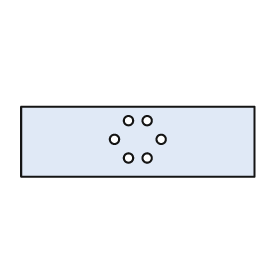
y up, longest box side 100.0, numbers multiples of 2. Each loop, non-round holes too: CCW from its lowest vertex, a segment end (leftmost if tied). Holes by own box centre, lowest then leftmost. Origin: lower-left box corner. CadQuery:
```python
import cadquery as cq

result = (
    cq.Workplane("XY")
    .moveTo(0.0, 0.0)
    .lineTo(100.0, 0.0)
    .lineTo(100.0, 30.0)
    .lineTo(0.0, 30.0)
    .close()
    .moveTo(46.0, 8.0)
    .circle(2.0)
    .moveTo(54.0, 8.0)
    .circle(2.0)
    .moveTo(40.0, 16.0)
    .circle(2.0)
    .moveTo(60.0, 16.0)
    .circle(2.0)
    .moveTo(46.0, 24.0)
    .circle(2.0)
    .moveTo(54.0, 24.0)
    .circle(2.0)
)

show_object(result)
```